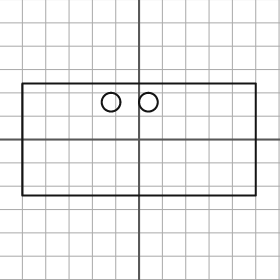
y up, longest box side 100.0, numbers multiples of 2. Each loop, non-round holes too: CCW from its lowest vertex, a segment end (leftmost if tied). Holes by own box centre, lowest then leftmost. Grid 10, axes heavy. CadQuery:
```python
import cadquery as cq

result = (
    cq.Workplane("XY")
    .moveTo(-50.0, -24.0)
    .lineTo(50.0, -24.0)
    .lineTo(50.0, 24.0)
    .lineTo(-50.0, 24.0)
    .close()
    .moveTo(-12.0, 16.0)
    .circle(4.0)
    .moveTo(4.0, 16.0)
    .circle(4.0)
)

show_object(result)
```